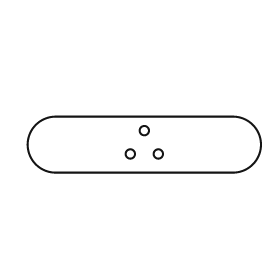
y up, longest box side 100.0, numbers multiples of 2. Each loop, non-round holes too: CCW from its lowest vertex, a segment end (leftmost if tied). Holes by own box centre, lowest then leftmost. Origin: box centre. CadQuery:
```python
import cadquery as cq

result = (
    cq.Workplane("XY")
    .moveTo(-38.0, -12.0)
    .lineTo(38.0, -12.0)
    .threePointArc((50.0, 0.0), (38.0, 12.0))
    .lineTo(-38.0, 12.0)
    .threePointArc((-50.0, 0.0), (-38.0, -12.0))
    .close()
    .moveTo(-6.0, -4.0)
    .circle(2.0)
    .moveTo(6.0, -4.0)
    .circle(2.0)
    .moveTo(0.0, 6.0)
    .circle(2.0)
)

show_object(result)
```